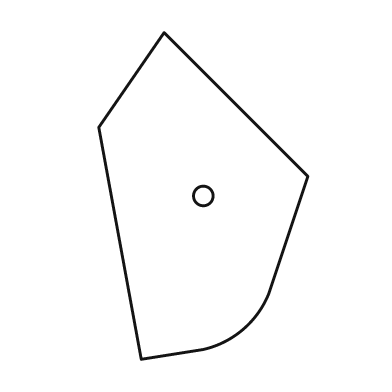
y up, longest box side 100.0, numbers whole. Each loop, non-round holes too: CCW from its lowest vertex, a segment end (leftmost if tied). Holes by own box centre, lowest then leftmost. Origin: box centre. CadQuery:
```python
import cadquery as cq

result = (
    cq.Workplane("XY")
    .moveTo(-19.0, -50.0)
    .lineTo(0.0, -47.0)
    .threePointArc((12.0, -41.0), (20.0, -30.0))
    .lineTo(32.0, 6.0)
    .lineTo(-12.0, 50.0)
    .lineTo(-32.0, 21.0)
    .close()
    .moveTo(0.0, 0.0)
    .circle(3.0)
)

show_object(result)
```